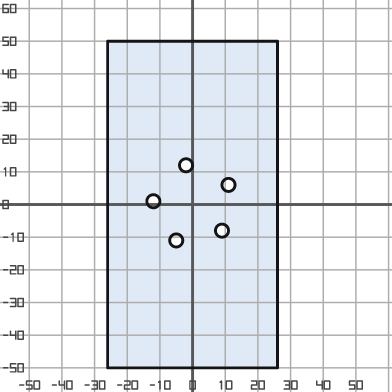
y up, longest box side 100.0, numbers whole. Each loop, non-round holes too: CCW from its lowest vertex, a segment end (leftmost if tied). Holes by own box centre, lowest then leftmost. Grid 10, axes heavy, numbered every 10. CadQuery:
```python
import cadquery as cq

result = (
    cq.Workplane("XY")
    .moveTo(-26.0, -50.0)
    .lineTo(26.0, -50.0)
    .lineTo(26.0, 50.0)
    .lineTo(-26.0, 50.0)
    .close()
    .moveTo(-5.0, -11.0)
    .circle(2.0)
    .moveTo(9.0, -8.0)
    .circle(2.0)
    .moveTo(-12.0, 1.0)
    .circle(2.0)
    .moveTo(11.0, 6.0)
    .circle(2.0)
    .moveTo(-2.0, 12.0)
    .circle(2.0)
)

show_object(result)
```